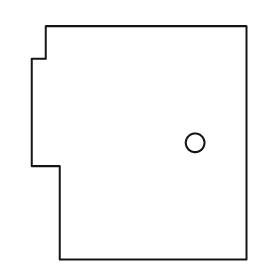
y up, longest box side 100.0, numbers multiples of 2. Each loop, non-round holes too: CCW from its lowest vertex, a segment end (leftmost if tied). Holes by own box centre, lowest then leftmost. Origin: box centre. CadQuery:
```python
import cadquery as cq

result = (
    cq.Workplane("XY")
    .moveTo(-34.0, -50.0)
    .lineTo(46.0, -50.0)
    .lineTo(46.0, 50.0)
    .lineTo(-40.0, 50.0)
    .lineTo(-40.0, 36.0)
    .lineTo(-46.0, 36.0)
    .lineTo(-46.0, -10.0)
    .lineTo(-34.0, -10.0)
    .close()
    .moveTo(24.0, 0.0)
    .circle(4.0)
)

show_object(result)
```